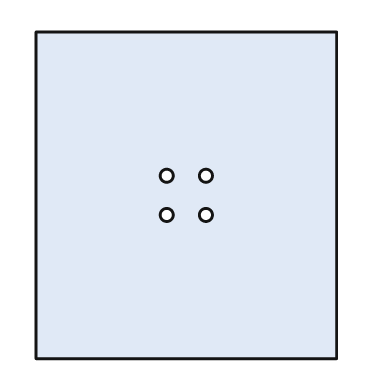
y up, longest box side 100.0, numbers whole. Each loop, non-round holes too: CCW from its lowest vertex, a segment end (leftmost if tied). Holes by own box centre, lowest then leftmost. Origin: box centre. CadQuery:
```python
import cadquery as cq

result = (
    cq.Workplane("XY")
    .moveTo(-46.0, -50.0)
    .lineTo(46.0, -50.0)
    .lineTo(46.0, 50.0)
    .lineTo(-46.0, 50.0)
    .close()
    .moveTo(-6.0, -6.0)
    .circle(2.0)
    .moveTo(6.0, -6.0)
    .circle(2.0)
    .moveTo(-6.0, 6.0)
    .circle(2.0)
    .moveTo(6.0, 6.0)
    .circle(2.0)
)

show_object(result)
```